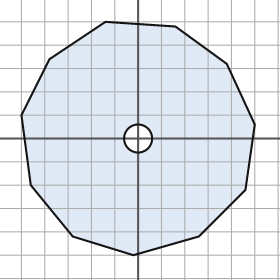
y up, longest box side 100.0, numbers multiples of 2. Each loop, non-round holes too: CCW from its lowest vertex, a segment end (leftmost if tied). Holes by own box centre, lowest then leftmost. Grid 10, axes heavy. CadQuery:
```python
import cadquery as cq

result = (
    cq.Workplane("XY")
    .moveTo(-2.0, -50.0)
    .lineTo(26.0, -42.0)
    .lineTo(46.0, -22.0)
    .lineTo(50.0, 6.0)
    .lineTo(38.0, 32.0)
    .lineTo(16.0, 48.0)
    .lineTo(-14.0, 50.0)
    .lineTo(-38.0, 34.0)
    .lineTo(-50.0, 10.0)
    .lineTo(-46.0, -20.0)
    .lineTo(-28.0, -42.0)
    .close()
    .moveTo(0.0, 0.0)
    .circle(6.0)
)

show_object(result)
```